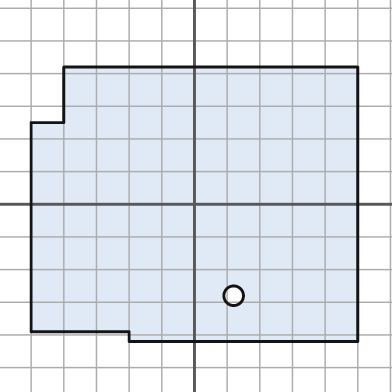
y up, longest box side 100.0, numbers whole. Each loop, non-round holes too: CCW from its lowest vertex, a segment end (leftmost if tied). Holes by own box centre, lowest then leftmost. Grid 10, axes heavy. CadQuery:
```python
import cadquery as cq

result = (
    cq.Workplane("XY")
    .moveTo(-20.0, -42.0)
    .lineTo(50.0, -42.0)
    .lineTo(50.0, 42.0)
    .lineTo(-40.0, 42.0)
    .lineTo(-40.0, 25.0)
    .lineTo(-50.0, 25.0)
    .lineTo(-50.0, -39.0)
    .lineTo(-20.0, -39.0)
    .close()
    .moveTo(12.0, -28.0)
    .circle(3.0)
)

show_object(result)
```